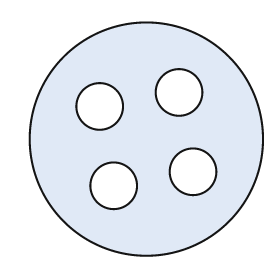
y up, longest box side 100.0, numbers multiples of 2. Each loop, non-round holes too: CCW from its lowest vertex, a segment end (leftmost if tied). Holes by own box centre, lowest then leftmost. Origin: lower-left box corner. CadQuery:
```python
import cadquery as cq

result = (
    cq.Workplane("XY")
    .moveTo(50.0, 50.0)
    .circle(50.0)
    .moveTo(36.0, 30.0)
    .circle(10.0)
    .moveTo(70.0, 36.0)
    .circle(10.0)
    .moveTo(30.0, 64.0)
    .circle(10.0)
    .moveTo(64.0, 70.0)
    .circle(10.0)
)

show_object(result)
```